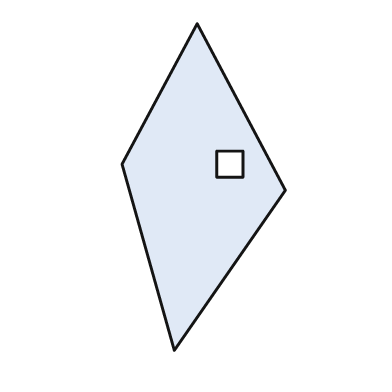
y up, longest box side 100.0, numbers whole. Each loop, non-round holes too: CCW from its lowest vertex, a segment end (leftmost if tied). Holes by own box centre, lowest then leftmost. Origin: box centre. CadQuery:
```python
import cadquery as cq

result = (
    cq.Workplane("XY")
    .moveTo(-9.0, -50.0)
    .lineTo(25.0, -1.0)
    .lineTo(-2.0, 50.0)
    .lineTo(-25.0, 7.0)
    .close()
    .moveTo(4.0, 3.0)
    .lineTo(12.0, 3.0)
    .lineTo(12.0, 11.0)
    .lineTo(4.0, 11.0)
    .close()
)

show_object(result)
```